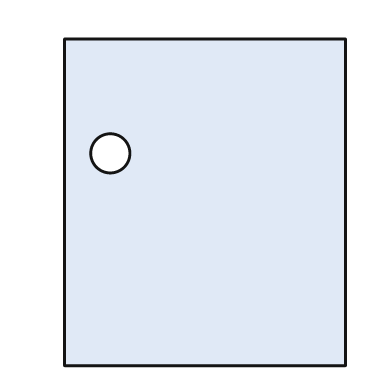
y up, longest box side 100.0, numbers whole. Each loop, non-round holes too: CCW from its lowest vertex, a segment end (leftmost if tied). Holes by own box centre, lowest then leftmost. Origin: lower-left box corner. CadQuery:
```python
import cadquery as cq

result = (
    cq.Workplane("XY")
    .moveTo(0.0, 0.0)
    .lineTo(86.0, 0.0)
    .lineTo(86.0, 100.0)
    .lineTo(0.0, 100.0)
    .close()
    .moveTo(14.0, 65.0)
    .circle(6.0)
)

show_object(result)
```